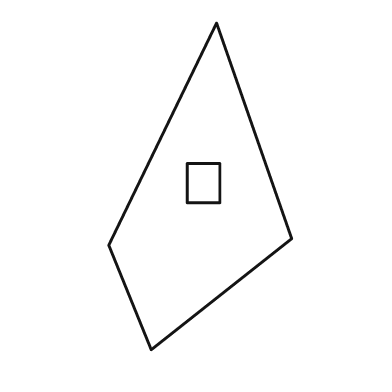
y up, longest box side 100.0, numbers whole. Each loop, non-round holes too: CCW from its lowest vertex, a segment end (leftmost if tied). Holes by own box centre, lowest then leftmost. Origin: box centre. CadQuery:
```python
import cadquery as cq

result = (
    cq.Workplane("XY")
    .moveTo(-15.0, -50.0)
    .lineTo(28.0, -16.0)
    .lineTo(5.0, 50.0)
    .lineTo(-28.0, -18.0)
    .close()
    .moveTo(-4.0, -5.0)
    .lineTo(6.0, -5.0)
    .lineTo(6.0, 7.0)
    .lineTo(-4.0, 7.0)
    .close()
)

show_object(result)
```